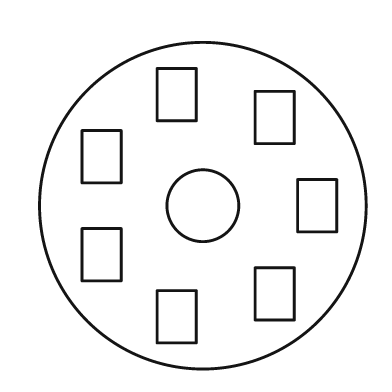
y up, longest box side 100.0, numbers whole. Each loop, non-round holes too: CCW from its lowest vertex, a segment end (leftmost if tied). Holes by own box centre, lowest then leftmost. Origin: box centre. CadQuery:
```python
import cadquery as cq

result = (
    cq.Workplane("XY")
    .moveTo(0.0, 0.0)
    .circle(50.0)
    .moveTo(-14.0, -42.0)
    .lineTo(-2.0, -42.0)
    .lineTo(-2.0, -26.0)
    .lineTo(-14.0, -26.0)
    .close()
    .moveTo(16.0, -35.0)
    .lineTo(28.0, -35.0)
    .lineTo(28.0, -19.0)
    .lineTo(16.0, -19.0)
    .close()
    .moveTo(-37.0, -23.0)
    .lineTo(-25.0, -23.0)
    .lineTo(-25.0, -7.0)
    .lineTo(-37.0, -7.0)
    .close()
    .moveTo(0.0, 0.0)
    .circle(11.0)
    .moveTo(29.0, -8.0)
    .lineTo(41.0, -8.0)
    .lineTo(41.0, 8.0)
    .lineTo(29.0, 8.0)
    .close()
    .moveTo(-37.0, 7.0)
    .lineTo(-25.0, 7.0)
    .lineTo(-25.0, 23.0)
    .lineTo(-37.0, 23.0)
    .close()
    .moveTo(16.0, 19.0)
    .lineTo(28.0, 19.0)
    .lineTo(28.0, 35.0)
    .lineTo(16.0, 35.0)
    .close()
    .moveTo(-14.0, 26.0)
    .lineTo(-2.0, 26.0)
    .lineTo(-2.0, 42.0)
    .lineTo(-14.0, 42.0)
    .close()
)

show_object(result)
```